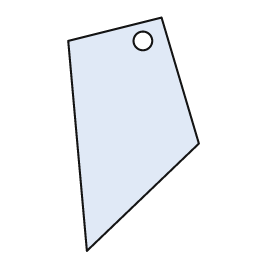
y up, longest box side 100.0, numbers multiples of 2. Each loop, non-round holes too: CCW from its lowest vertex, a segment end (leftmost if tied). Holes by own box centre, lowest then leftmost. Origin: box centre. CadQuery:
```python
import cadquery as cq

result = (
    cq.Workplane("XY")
    .moveTo(-20.0, -50.0)
    .lineTo(28.0, -4.0)
    .lineTo(12.0, 50.0)
    .lineTo(-28.0, 40.0)
    .close()
    .moveTo(4.0, 40.0)
    .circle(4.0)
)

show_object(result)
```